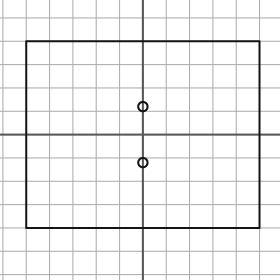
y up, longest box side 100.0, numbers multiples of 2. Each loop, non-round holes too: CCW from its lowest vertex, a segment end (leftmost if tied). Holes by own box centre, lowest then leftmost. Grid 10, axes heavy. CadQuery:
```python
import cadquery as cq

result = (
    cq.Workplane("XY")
    .moveTo(-50.0, -40.0)
    .lineTo(50.0, -40.0)
    .lineTo(50.0, 40.0)
    .lineTo(-50.0, 40.0)
    .close()
    .moveTo(0.0, -12.0)
    .circle(2.0)
    .moveTo(0.0, 12.0)
    .circle(2.0)
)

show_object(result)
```